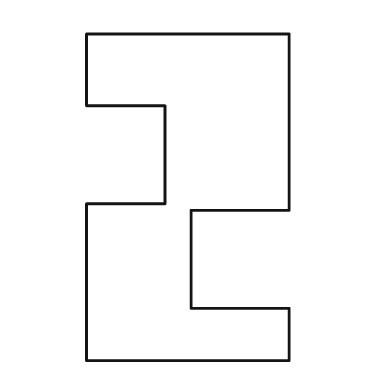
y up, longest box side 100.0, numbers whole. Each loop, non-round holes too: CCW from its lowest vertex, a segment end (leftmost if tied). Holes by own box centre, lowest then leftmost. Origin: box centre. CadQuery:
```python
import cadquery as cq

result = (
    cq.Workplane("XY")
    .moveTo(-31.0, -50.0)
    .lineTo(31.0, -50.0)
    .lineTo(31.0, -34.0)
    .lineTo(1.0, -34.0)
    .lineTo(1.0, -4.0)
    .lineTo(31.0, -4.0)
    .lineTo(31.0, 50.0)
    .lineTo(-31.0, 50.0)
    .lineTo(-31.0, 28.0)
    .lineTo(-7.0, 28.0)
    .lineTo(-7.0, -2.0)
    .lineTo(-31.0, -2.0)
    .close()
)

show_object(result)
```